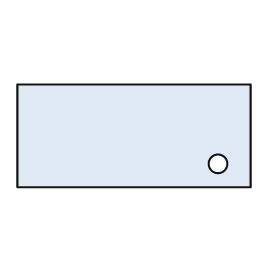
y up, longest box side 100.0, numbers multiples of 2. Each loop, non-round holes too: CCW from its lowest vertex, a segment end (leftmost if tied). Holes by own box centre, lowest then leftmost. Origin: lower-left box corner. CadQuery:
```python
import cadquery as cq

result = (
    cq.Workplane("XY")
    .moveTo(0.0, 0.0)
    .lineTo(100.0, 0.0)
    .lineTo(100.0, 44.0)
    .lineTo(0.0, 44.0)
    .close()
    .moveTo(86.0, 10.0)
    .circle(4.0)
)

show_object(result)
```